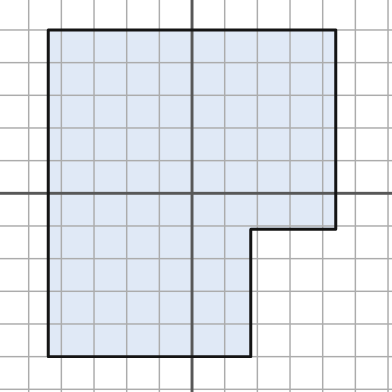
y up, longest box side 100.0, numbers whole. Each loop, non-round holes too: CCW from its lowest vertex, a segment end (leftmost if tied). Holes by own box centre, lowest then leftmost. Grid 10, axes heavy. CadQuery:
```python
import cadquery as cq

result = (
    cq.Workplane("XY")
    .moveTo(-44.0, -50.0)
    .lineTo(18.0, -50.0)
    .lineTo(18.0, -11.0)
    .lineTo(44.0, -11.0)
    .lineTo(44.0, 50.0)
    .lineTo(-44.0, 50.0)
    .close()
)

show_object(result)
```